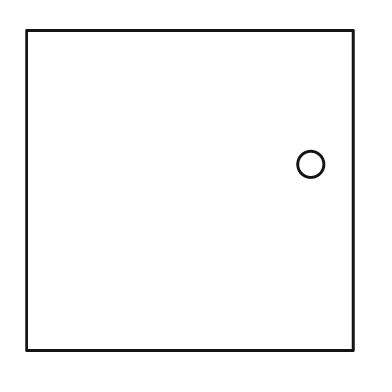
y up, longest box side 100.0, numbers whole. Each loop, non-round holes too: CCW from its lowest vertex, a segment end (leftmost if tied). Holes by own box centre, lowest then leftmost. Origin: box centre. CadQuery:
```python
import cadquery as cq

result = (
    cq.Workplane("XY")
    .moveTo(-50.0, -49.0)
    .lineTo(50.0, -49.0)
    .lineTo(50.0, 49.0)
    .lineTo(-50.0, 49.0)
    .close()
    .moveTo(37.0, 8.0)
    .circle(4.0)
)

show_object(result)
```